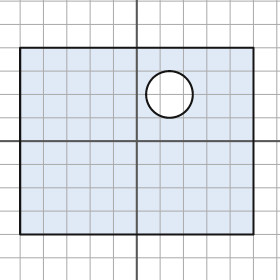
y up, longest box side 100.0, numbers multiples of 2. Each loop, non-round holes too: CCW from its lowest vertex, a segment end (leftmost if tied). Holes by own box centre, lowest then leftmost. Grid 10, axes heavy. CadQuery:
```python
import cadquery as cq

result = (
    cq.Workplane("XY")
    .moveTo(-50.0, -40.0)
    .lineTo(50.0, -40.0)
    .lineTo(50.0, 40.0)
    .lineTo(-50.0, 40.0)
    .close()
    .moveTo(14.0, 20.0)
    .circle(10.0)
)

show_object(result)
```